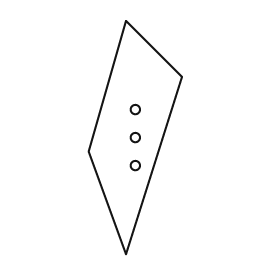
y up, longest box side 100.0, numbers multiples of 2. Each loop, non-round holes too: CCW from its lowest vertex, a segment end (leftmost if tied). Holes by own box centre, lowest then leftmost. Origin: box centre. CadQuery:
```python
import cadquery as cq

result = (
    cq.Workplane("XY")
    .moveTo(-4.0, -50.0)
    .lineTo(20.0, 26.0)
    .lineTo(-4.0, 50.0)
    .lineTo(-20.0, -6.0)
    .close()
    .moveTo(0.0, -12.0)
    .circle(2.0)
    .moveTo(0.0, 0.0)
    .circle(2.0)
    .moveTo(0.0, 12.0)
    .circle(2.0)
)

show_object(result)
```